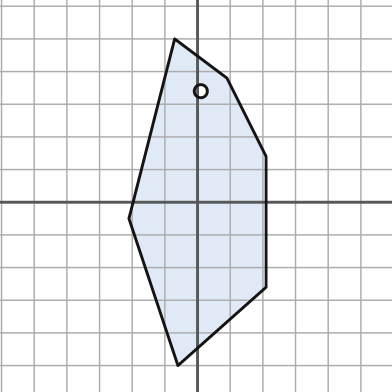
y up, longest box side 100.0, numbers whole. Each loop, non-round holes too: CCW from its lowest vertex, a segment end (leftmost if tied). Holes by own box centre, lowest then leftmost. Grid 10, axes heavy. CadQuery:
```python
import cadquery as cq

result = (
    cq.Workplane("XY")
    .moveTo(-6.0, -50.0)
    .lineTo(21.0, -26.0)
    .lineTo(21.0, 14.0)
    .lineTo(9.0, 38.0)
    .lineTo(-7.0, 50.0)
    .lineTo(-21.0, -5.0)
    .close()
    .moveTo(1.0, 34.0)
    .circle(2.0)
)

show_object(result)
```